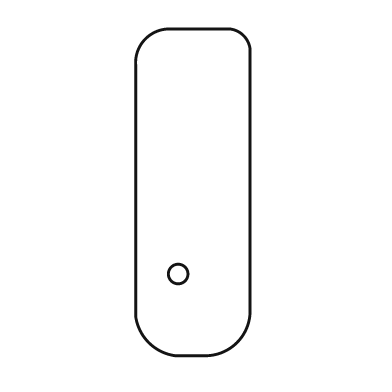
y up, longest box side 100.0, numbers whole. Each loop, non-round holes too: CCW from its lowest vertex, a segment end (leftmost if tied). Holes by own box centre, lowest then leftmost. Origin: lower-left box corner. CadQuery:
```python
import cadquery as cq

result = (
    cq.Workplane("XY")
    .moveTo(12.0, 0.0)
    .lineTo(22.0, 0.0)
    .threePointArc((31.0, 4.0), (35.0, 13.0))
    .lineTo(35.0, 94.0)
    .threePointArc((33.0, 98.0), (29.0, 100.0))
    .lineTo(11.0, 100.0)
    .threePointArc((3.0, 97.0), (0.0, 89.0))
    .lineTo(0.0, 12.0)
    .threePointArc((4.0, 4.0), (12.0, 0.0))
    .close()
    .moveTo(13.0, 25.0)
    .circle(3.0)
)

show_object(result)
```